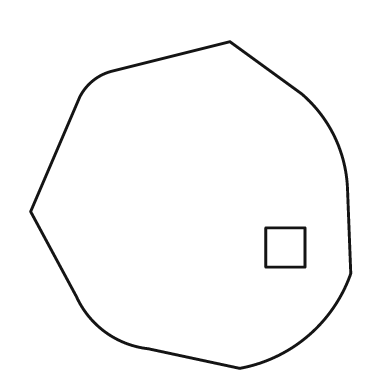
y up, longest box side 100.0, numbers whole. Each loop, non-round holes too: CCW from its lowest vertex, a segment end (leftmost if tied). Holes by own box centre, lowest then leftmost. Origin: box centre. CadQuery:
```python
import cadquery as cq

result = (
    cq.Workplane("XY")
    .moveTo(15.0, -50.0)
    .threePointArc((36.0, -40.0), (49.0, -21.0))
    .lineTo(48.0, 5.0)
    .threePointArc((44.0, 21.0), (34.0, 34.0))
    .lineTo(12.0, 50.0)
    .lineTo(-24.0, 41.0)
    .threePointArc((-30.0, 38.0), (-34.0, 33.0))
    .lineTo(-49.0, -2.0)
    .lineTo(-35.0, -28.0)
    .threePointArc((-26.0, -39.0), (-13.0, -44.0))
    .close()
    .moveTo(23.0, -19.0)
    .lineTo(35.0, -19.0)
    .lineTo(35.0, -7.0)
    .lineTo(23.0, -7.0)
    .close()
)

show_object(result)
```